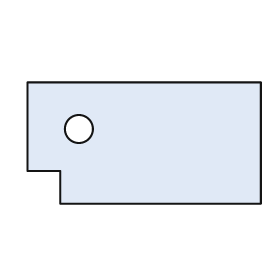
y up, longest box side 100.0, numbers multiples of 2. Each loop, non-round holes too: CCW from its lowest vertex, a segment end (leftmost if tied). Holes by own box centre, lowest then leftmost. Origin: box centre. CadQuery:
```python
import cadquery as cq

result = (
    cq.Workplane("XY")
    .moveTo(-36.0, -26.0)
    .lineTo(50.0, -26.0)
    .lineTo(50.0, 26.0)
    .lineTo(-50.0, 26.0)
    .lineTo(-50.0, -12.0)
    .lineTo(-36.0, -12.0)
    .close()
    .moveTo(-28.0, 6.0)
    .circle(6.0)
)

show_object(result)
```